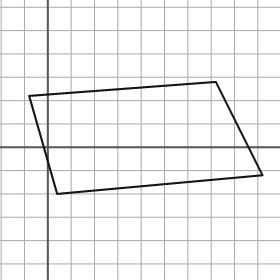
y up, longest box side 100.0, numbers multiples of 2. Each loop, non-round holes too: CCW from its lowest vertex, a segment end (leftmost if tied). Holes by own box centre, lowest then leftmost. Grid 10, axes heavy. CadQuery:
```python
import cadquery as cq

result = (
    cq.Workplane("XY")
    .moveTo(4.0, -20.0)
    .lineTo(92.0, -12.0)
    .lineTo(72.0, 28.0)
    .lineTo(-8.0, 22.0)
    .close()
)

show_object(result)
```